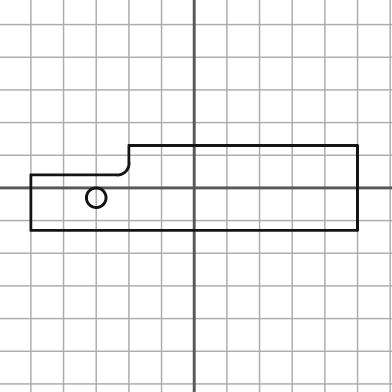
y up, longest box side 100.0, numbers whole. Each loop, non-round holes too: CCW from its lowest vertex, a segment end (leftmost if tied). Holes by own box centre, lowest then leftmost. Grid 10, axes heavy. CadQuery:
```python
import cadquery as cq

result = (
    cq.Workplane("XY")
    .moveTo(-50.0, -13.0)
    .lineTo(50.0, -13.0)
    .lineTo(50.0, 13.0)
    .lineTo(-20.0, 13.0)
    .lineTo(-20.0, 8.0)
    .threePointArc((-21.0, 5.0), (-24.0, 4.0))
    .lineTo(-50.0, 4.0)
    .close()
    .moveTo(-30.0, -3.0)
    .circle(3.0)
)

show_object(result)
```